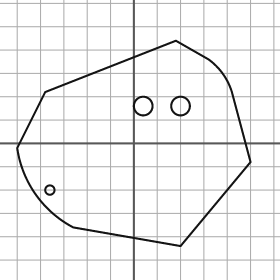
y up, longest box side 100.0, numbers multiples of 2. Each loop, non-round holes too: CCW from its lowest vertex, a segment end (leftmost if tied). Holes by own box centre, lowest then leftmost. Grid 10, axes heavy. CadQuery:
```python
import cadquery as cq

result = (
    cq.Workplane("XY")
    .moveTo(20.0, -44.0)
    .lineTo(50.0, -8.0)
    .lineTo(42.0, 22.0)
    .threePointArc((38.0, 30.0), (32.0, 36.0))
    .lineTo(18.0, 44.0)
    .lineTo(-38.0, 22.0)
    .lineTo(-50.0, -2.0)
    .threePointArc((-42.0, -22.0), (-26.0, -36.0))
    .close()
    .moveTo(-36.0, -20.0)
    .circle(2.0)
    .moveTo(4.0, 16.0)
    .circle(4.0)
    .moveTo(20.0, 16.0)
    .circle(4.0)
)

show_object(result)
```